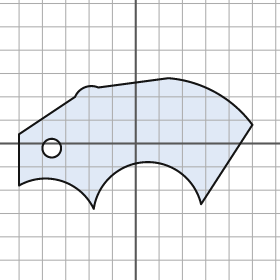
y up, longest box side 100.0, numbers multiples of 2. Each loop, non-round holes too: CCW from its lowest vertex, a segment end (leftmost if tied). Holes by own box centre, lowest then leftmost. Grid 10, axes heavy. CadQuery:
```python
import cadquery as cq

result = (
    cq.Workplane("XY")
    .moveTo(-18.0, -28.0)
    .threePointArc((4.0, -8.0), (28.0, -26.0))
    .lineTo(50.0, 8.0)
    .threePointArc((34.0, 22.0), (14.0, 28.0))
    .lineTo(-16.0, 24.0)
    .threePointArc((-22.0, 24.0), (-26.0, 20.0))
    .lineTo(-50.0, 4.0)
    .lineTo(-50.0, -18.0)
    .threePointArc((-32.0, -16.0), (-18.0, -28.0))
    .close()
    .moveTo(-36.0, -2.0)
    .circle(4.0)
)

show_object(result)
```